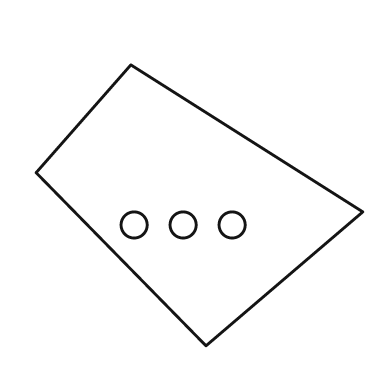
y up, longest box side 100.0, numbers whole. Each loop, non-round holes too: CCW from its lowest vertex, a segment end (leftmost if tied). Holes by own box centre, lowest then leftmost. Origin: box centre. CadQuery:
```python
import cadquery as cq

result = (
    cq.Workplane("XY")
    .moveTo(2.0, -43.0)
    .lineTo(50.0, -2.0)
    .lineTo(-21.0, 43.0)
    .lineTo(-50.0, 10.0)
    .close()
    .moveTo(-20.0, -6.0)
    .circle(4.0)
    .moveTo(-5.0, -6.0)
    .circle(4.0)
    .moveTo(10.0, -6.0)
    .circle(4.0)
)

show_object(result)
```